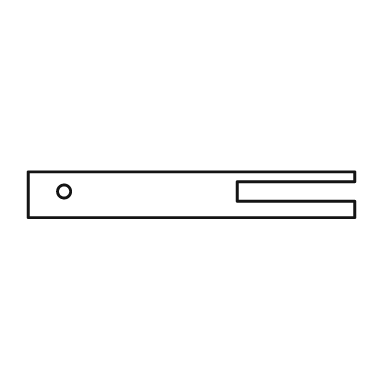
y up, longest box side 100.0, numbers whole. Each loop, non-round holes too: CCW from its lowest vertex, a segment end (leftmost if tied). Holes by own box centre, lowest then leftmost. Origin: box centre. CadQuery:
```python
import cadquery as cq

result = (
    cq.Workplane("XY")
    .moveTo(-50.0, -7.0)
    .lineTo(50.0, -7.0)
    .lineTo(50.0, -2.0)
    .lineTo(14.0, -2.0)
    .lineTo(14.0, 4.0)
    .lineTo(50.0, 4.0)
    .lineTo(50.0, 7.0)
    .lineTo(-50.0, 7.0)
    .close()
    .moveTo(-39.0, 1.0)
    .circle(2.0)
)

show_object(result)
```